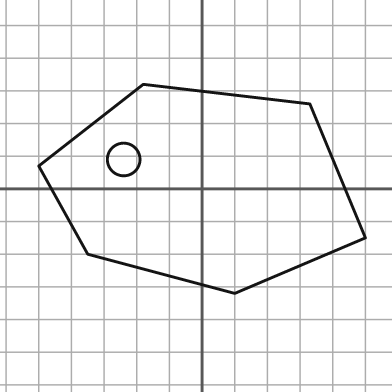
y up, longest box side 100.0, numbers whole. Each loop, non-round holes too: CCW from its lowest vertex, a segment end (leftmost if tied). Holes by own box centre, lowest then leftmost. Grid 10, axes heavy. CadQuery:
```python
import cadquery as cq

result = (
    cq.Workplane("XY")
    .moveTo(10.0, -32.0)
    .lineTo(50.0, -15.0)
    .lineTo(33.0, 26.0)
    .lineTo(-18.0, 32.0)
    .lineTo(-50.0, 7.0)
    .lineTo(-35.0, -20.0)
    .close()
    .moveTo(-24.0, 9.0)
    .circle(5.0)
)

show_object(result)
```